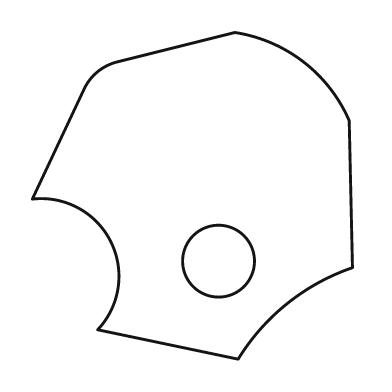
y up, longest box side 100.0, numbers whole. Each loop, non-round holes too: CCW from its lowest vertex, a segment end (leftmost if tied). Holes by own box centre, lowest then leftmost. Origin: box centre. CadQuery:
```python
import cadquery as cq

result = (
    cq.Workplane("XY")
    .moveTo(14.0, -50.0)
    .threePointArc((29.0, -33.0), (49.0, -22.0))
    .lineTo(48.0, 23.0)
    .threePointArc((34.0, 41.0), (13.0, 50.0))
    .lineTo(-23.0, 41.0)
    .threePointArc((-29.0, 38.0), (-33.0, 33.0))
    .lineTo(-49.0, -1.0)
    .threePointArc((-25.0, -14.0), (-29.0, -41.0))
    .close()
    .moveTo(8.0, -20.0)
    .circle(11.0)
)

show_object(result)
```